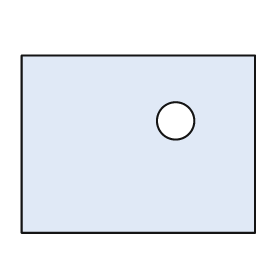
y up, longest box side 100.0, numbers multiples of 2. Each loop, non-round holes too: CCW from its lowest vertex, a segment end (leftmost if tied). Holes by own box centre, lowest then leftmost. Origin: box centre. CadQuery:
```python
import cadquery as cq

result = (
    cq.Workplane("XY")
    .moveTo(-50.0, -38.0)
    .lineTo(50.0, -38.0)
    .lineTo(50.0, 38.0)
    .lineTo(-50.0, 38.0)
    .close()
    .moveTo(16.0, 10.0)
    .circle(8.0)
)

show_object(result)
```